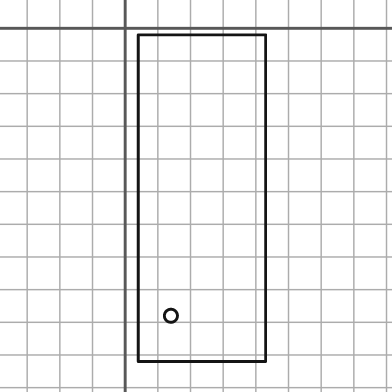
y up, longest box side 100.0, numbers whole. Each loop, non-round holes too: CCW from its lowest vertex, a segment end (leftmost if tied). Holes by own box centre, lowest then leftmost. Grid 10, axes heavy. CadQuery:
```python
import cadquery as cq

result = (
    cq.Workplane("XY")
    .moveTo(4.0, -102.0)
    .lineTo(43.0, -102.0)
    .lineTo(43.0, -2.0)
    .lineTo(4.0, -2.0)
    .close()
    .moveTo(14.0, -88.0)
    .circle(2.0)
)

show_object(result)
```